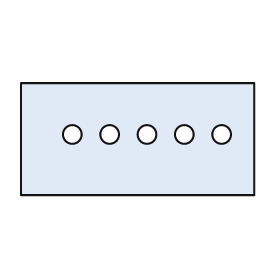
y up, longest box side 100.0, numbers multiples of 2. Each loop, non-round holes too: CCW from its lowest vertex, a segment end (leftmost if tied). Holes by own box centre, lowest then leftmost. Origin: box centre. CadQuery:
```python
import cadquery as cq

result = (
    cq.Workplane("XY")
    .moveTo(-50.0, -24.0)
    .lineTo(50.0, -24.0)
    .lineTo(50.0, 24.0)
    .lineTo(-50.0, 24.0)
    .close()
    .moveTo(-28.0, 2.0)
    .circle(4.0)
    .moveTo(-12.0, 2.0)
    .circle(4.0)
    .moveTo(4.0, 2.0)
    .circle(4.0)
    .moveTo(20.0, 2.0)
    .circle(4.0)
    .moveTo(36.0, 2.0)
    .circle(4.0)
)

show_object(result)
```